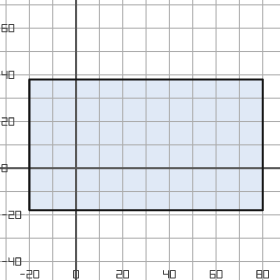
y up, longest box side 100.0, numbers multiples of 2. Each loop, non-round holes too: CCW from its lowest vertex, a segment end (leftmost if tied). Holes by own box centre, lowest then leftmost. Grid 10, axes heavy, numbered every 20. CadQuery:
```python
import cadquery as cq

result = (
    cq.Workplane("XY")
    .moveTo(-20.0, -18.0)
    .lineTo(80.0, -18.0)
    .lineTo(80.0, 38.0)
    .lineTo(-20.0, 38.0)
    .close()
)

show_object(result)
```